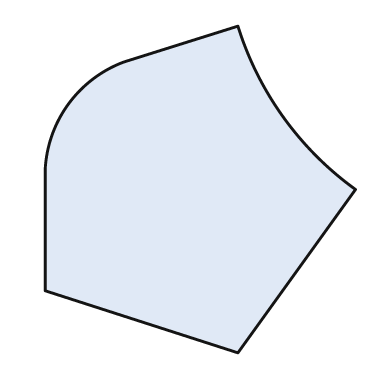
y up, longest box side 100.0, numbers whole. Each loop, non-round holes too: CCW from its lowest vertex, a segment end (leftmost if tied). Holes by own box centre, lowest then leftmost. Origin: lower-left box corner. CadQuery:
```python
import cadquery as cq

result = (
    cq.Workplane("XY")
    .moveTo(59.0, 0.0)
    .lineTo(95.0, 50.0)
    .threePointArc((73.0, 72.0), (59.0, 100.0))
    .lineTo(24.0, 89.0)
    .threePointArc((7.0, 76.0), (0.0, 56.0))
    .lineTo(0.0, 19.0)
    .close()
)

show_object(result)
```